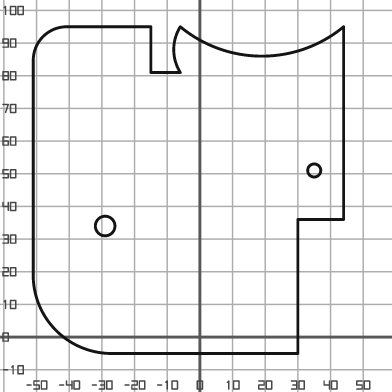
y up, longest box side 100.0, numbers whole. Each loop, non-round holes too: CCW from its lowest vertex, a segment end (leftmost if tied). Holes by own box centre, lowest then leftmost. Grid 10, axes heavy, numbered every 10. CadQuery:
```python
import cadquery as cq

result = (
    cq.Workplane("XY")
    .moveTo(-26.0, -5.0)
    .lineTo(30.0, -5.0)
    .lineTo(30.0, 36.0)
    .lineTo(44.0, 36.0)
    .lineTo(44.0, 95.0)
    .threePointArc((19.0, 86.0), (-6.0, 95.0))
    .threePointArc((-8.0, 88.0), (-6.0, 81.0))
    .lineTo(-15.0, 81.0)
    .lineTo(-15.0, 95.0)
    .lineTo(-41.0, 95.0)
    .threePointArc((-48.0, 92.0), (-51.0, 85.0))
    .lineTo(-51.0, 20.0)
    .threePointArc((-44.0, 2.0), (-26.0, -5.0))
    .close()
    .moveTo(-29.0, 34.0)
    .circle(3.0)
    .moveTo(35.0, 51.0)
    .circle(2.0)
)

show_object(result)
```